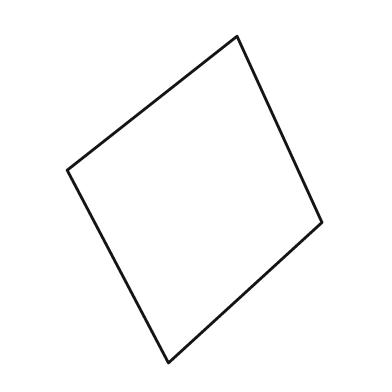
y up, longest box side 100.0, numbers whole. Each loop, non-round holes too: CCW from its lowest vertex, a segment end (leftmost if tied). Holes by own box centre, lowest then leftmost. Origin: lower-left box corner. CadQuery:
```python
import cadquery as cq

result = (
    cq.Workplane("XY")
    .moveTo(31.0, 0.0)
    .lineTo(78.0, 43.0)
    .lineTo(52.0, 100.0)
    .lineTo(0.0, 59.0)
    .close()
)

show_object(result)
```